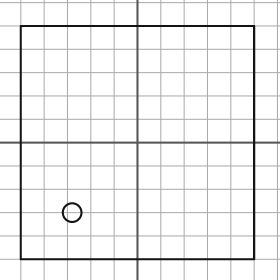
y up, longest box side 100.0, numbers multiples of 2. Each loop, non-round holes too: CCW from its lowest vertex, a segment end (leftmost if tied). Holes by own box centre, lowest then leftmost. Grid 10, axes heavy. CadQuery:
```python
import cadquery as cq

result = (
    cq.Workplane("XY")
    .moveTo(-50.0, -50.0)
    .lineTo(50.0, -50.0)
    .lineTo(50.0, 50.0)
    .lineTo(-50.0, 50.0)
    .close()
    .moveTo(-28.0, -30.0)
    .circle(4.0)
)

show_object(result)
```